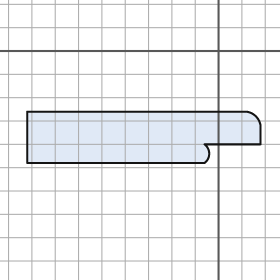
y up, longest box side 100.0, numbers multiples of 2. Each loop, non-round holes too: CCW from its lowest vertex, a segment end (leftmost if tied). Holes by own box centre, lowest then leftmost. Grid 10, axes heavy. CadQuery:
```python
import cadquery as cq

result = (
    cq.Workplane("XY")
    .moveTo(-82.0, -48.0)
    .lineTo(-6.0, -48.0)
    .threePointArc((-4.0, -44.0), (-6.0, -40.0))
    .lineTo(18.0, -40.0)
    .lineTo(18.0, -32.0)
    .threePointArc((16.0, -28.0), (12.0, -26.0))
    .lineTo(-82.0, -26.0)
    .close()
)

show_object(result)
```